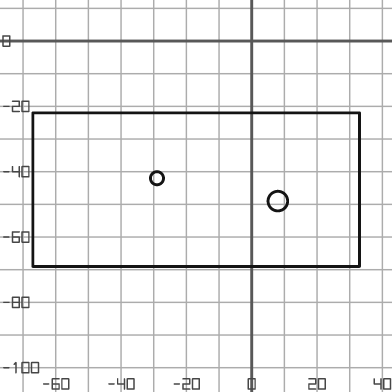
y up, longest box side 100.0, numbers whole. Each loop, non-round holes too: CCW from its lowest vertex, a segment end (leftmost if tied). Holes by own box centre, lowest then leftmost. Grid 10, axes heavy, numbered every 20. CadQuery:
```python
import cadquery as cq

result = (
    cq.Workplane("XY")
    .moveTo(-67.0, -69.0)
    .lineTo(33.0, -69.0)
    .lineTo(33.0, -22.0)
    .lineTo(-67.0, -22.0)
    .close()
    .moveTo(8.0, -49.0)
    .circle(3.0)
    .moveTo(-29.0, -42.0)
    .circle(2.0)
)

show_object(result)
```